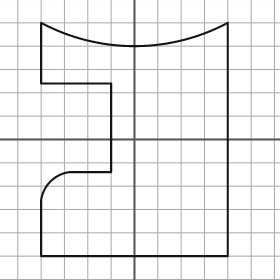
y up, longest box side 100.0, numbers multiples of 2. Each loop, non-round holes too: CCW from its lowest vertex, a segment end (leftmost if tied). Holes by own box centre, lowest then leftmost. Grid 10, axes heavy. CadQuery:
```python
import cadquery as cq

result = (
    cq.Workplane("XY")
    .moveTo(-40.0, -50.0)
    .lineTo(40.0, -50.0)
    .lineTo(40.0, 50.0)
    .threePointArc((0.0, 40.0), (-40.0, 50.0))
    .lineTo(-40.0, 24.0)
    .lineTo(-10.0, 24.0)
    .lineTo(-10.0, -14.0)
    .lineTo(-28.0, -14.0)
    .threePointArc((-36.0, -18.0), (-40.0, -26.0))
    .close()
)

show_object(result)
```